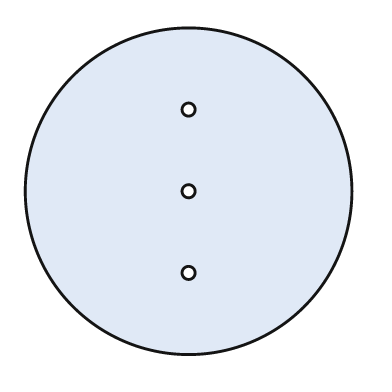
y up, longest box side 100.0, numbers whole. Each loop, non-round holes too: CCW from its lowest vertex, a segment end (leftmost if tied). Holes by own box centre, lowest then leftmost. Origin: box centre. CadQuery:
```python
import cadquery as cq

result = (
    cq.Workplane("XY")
    .moveTo(0.0, 0.0)
    .circle(50.0)
    .moveTo(0.0, -25.0)
    .circle(2.0)
    .moveTo(0.0, 0.0)
    .circle(2.0)
    .moveTo(0.0, 25.0)
    .circle(2.0)
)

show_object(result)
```